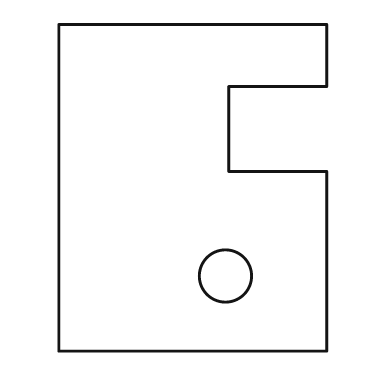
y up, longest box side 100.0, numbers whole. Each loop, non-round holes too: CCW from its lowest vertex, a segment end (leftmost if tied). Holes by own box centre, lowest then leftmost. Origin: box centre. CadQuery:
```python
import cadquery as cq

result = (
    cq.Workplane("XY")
    .moveTo(-41.0, -50.0)
    .lineTo(41.0, -50.0)
    .lineTo(41.0, 5.0)
    .lineTo(11.0, 5.0)
    .lineTo(11.0, 31.0)
    .lineTo(41.0, 31.0)
    .lineTo(41.0, 50.0)
    .lineTo(-41.0, 50.0)
    .close()
    .moveTo(10.0, -27.0)
    .circle(8.0)
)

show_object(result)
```